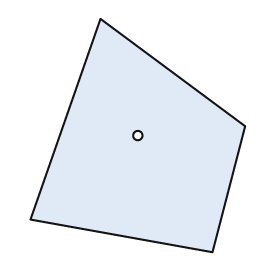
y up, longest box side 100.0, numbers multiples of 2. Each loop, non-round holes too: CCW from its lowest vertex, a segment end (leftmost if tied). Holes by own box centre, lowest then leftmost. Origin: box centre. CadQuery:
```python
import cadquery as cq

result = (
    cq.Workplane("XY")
    .moveTo(32.0, -50.0)
    .lineTo(46.0, 4.0)
    .lineTo(-16.0, 50.0)
    .lineTo(-46.0, -36.0)
    .close()
    .moveTo(0.0, 0.0)
    .circle(2.0)
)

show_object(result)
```